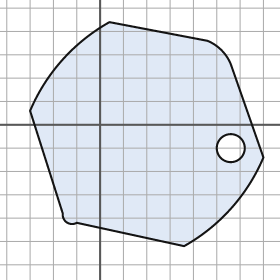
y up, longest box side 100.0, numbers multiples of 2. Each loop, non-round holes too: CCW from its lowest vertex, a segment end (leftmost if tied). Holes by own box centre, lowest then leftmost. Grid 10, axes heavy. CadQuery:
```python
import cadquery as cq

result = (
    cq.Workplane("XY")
    .moveTo(36.0, -52.0)
    .threePointArc((56.0, -36.0), (70.0, -14.0))
    .lineTo(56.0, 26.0)
    .threePointArc((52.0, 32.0), (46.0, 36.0))
    .lineTo(4.0, 44.0)
    .threePointArc((-16.0, 28.0), (-30.0, 6.0))
    .lineTo(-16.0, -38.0)
    .threePointArc((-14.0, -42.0), (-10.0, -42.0))
    .close()
    .moveTo(56.0, -10.0)
    .circle(6.0)
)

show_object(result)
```